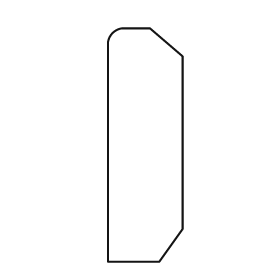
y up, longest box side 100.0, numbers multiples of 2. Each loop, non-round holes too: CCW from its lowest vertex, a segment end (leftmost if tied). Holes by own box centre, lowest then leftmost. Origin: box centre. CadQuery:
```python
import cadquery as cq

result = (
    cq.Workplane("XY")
    .moveTo(-16.0, -50.0)
    .lineTo(6.0, -50.0)
    .lineTo(16.0, -36.0)
    .lineTo(16.0, 38.0)
    .lineTo(2.0, 50.0)
    .lineTo(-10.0, 50.0)
    .threePointArc((-14.0, 48.0), (-16.0, 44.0))
    .close()
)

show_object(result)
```